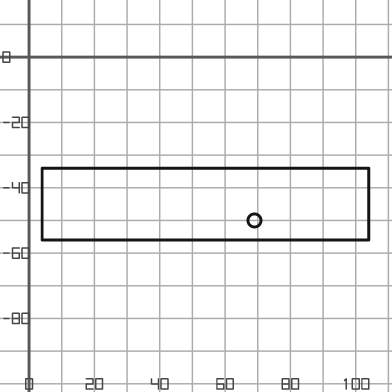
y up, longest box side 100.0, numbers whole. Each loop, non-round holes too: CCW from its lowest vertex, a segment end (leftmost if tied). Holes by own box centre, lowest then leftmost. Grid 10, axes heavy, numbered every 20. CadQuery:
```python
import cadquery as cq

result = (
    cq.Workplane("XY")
    .moveTo(4.0, -56.0)
    .lineTo(104.0, -56.0)
    .lineTo(104.0, -34.0)
    .lineTo(4.0, -34.0)
    .close()
    .moveTo(69.0, -50.0)
    .circle(2.0)
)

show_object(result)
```